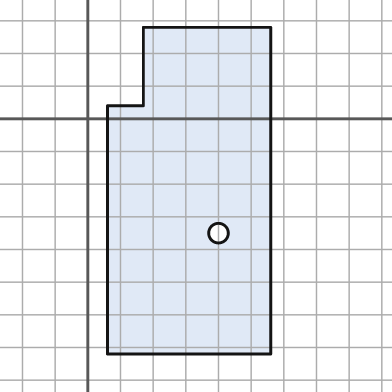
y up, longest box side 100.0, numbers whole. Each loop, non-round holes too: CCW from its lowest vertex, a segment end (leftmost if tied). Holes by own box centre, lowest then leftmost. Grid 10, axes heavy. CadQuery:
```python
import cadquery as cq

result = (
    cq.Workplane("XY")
    .moveTo(6.0, -72.0)
    .lineTo(56.0, -72.0)
    .lineTo(56.0, 28.0)
    .lineTo(17.0, 28.0)
    .lineTo(17.0, 4.0)
    .lineTo(6.0, 4.0)
    .close()
    .moveTo(40.0, -35.0)
    .circle(3.0)
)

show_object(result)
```